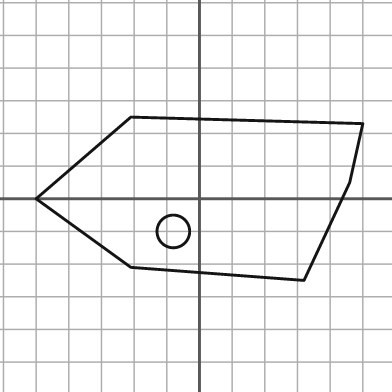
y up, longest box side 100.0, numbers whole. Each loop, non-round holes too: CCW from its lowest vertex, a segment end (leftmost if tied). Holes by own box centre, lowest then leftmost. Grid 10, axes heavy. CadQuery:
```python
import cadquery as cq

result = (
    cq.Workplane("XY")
    .moveTo(32.0, -25.0)
    .lineTo(46.0, 5.0)
    .lineTo(50.0, 23.0)
    .lineTo(-21.0, 25.0)
    .lineTo(-50.0, 0.0)
    .lineTo(-21.0, -21.0)
    .close()
    .moveTo(-8.0, -10.0)
    .circle(5.0)
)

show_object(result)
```